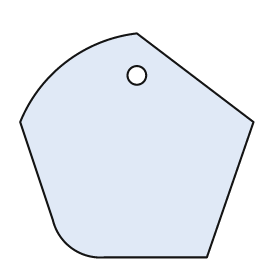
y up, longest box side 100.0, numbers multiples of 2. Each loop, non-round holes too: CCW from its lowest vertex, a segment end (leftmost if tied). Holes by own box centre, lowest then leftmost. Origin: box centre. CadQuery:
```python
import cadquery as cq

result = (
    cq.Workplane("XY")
    .moveTo(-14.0, -48.0)
    .lineTo(30.0, -48.0)
    .lineTo(50.0, 10.0)
    .lineTo(0.0, 48.0)
    .threePointArc((-30.0, 36.0), (-50.0, 10.0))
    .lineTo(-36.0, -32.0)
    .threePointArc((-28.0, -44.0), (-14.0, -48.0))
    .close()
    .moveTo(0.0, 30.0)
    .circle(4.0)
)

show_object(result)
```